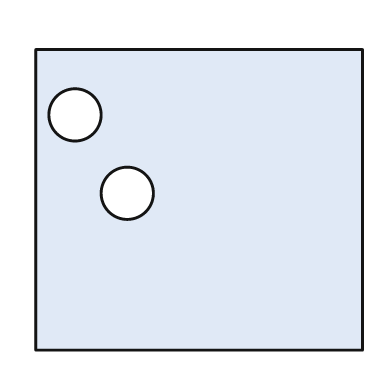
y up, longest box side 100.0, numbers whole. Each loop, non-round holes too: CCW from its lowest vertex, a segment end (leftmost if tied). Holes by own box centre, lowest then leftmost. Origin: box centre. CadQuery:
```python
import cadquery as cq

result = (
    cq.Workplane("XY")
    .moveTo(-50.0, -46.0)
    .lineTo(50.0, -46.0)
    .lineTo(50.0, 46.0)
    .lineTo(-50.0, 46.0)
    .close()
    .moveTo(-22.0, 2.0)
    .circle(8.0)
    .moveTo(-38.0, 26.0)
    .circle(8.0)
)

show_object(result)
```